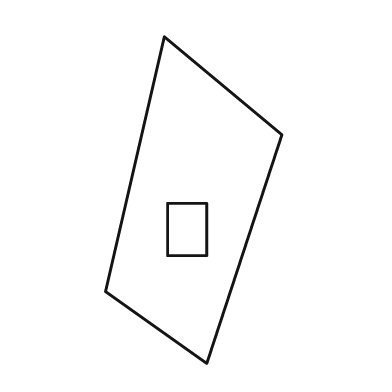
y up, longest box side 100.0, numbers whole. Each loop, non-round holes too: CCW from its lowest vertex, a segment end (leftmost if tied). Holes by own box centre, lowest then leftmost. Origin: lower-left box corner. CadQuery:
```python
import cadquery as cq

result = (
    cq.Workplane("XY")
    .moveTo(31.0, 0.0)
    .lineTo(54.0, 70.0)
    .lineTo(18.0, 100.0)
    .lineTo(0.0, 22.0)
    .close()
    .moveTo(19.0, 33.0)
    .lineTo(31.0, 33.0)
    .lineTo(31.0, 49.0)
    .lineTo(19.0, 49.0)
    .close()
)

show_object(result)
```